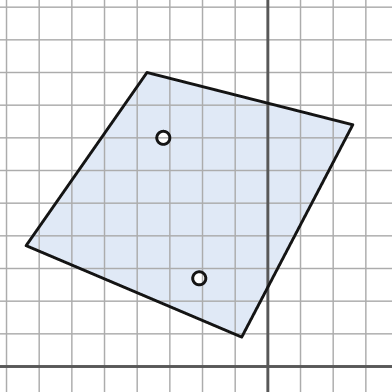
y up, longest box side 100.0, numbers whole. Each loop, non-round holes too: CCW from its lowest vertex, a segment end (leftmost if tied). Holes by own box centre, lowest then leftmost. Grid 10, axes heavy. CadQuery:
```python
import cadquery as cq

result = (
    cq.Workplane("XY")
    .moveTo(-8.0, 9.0)
    .lineTo(26.0, 74.0)
    .lineTo(-37.0, 90.0)
    .lineTo(-74.0, 37.0)
    .close()
    .moveTo(-21.0, 27.0)
    .circle(2.0)
    .moveTo(-32.0, 70.0)
    .circle(2.0)
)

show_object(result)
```